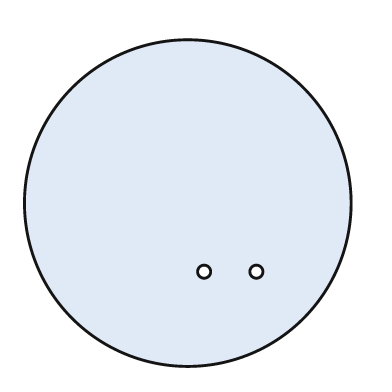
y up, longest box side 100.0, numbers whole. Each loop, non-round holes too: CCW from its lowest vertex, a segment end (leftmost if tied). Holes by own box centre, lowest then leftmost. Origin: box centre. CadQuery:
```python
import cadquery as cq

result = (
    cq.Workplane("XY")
    .moveTo(0.0, 0.0)
    .circle(50.0)
    .moveTo(5.0, -21.0)
    .circle(2.0)
    .moveTo(21.0, -21.0)
    .circle(2.0)
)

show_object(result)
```